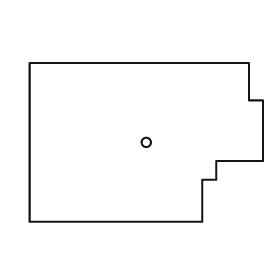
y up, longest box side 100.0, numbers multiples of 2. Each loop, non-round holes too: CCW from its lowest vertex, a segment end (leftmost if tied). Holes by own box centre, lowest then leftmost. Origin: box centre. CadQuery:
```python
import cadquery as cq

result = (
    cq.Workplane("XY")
    .moveTo(-50.0, -34.0)
    .lineTo(24.0, -34.0)
    .lineTo(24.0, -16.0)
    .lineTo(30.0, -16.0)
    .lineTo(30.0, -8.0)
    .lineTo(50.0, -8.0)
    .lineTo(50.0, 18.0)
    .lineTo(44.0, 18.0)
    .lineTo(44.0, 34.0)
    .lineTo(-50.0, 34.0)
    .close()
    .moveTo(0.0, 0.0)
    .circle(2.0)
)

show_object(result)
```